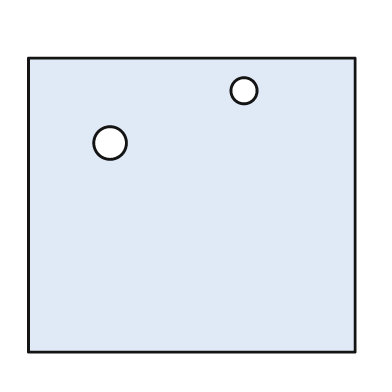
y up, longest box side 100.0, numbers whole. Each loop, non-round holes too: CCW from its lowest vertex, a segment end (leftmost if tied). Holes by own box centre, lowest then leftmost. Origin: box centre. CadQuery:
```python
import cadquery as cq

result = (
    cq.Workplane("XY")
    .moveTo(-50.0, -45.0)
    .lineTo(50.0, -45.0)
    .lineTo(50.0, 45.0)
    .lineTo(-50.0, 45.0)
    .close()
    .moveTo(-25.0, 19.0)
    .circle(5.0)
    .moveTo(16.0, 35.0)
    .circle(4.0)
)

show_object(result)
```